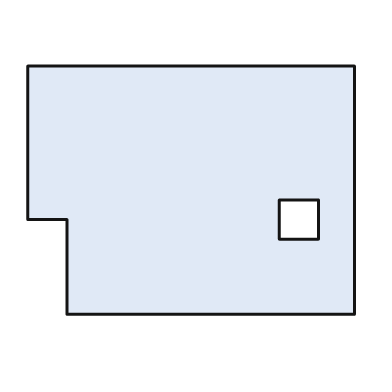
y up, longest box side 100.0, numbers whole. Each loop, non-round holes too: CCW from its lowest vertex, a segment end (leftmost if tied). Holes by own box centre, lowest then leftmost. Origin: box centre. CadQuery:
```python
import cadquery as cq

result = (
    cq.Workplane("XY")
    .moveTo(-38.0, -38.0)
    .lineTo(50.0, -38.0)
    .lineTo(50.0, 38.0)
    .lineTo(-50.0, 38.0)
    .lineTo(-50.0, -9.0)
    .lineTo(-38.0, -9.0)
    .close()
    .moveTo(27.0, -15.0)
    .lineTo(39.0, -15.0)
    .lineTo(39.0, -3.0)
    .lineTo(27.0, -3.0)
    .close()
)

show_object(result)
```